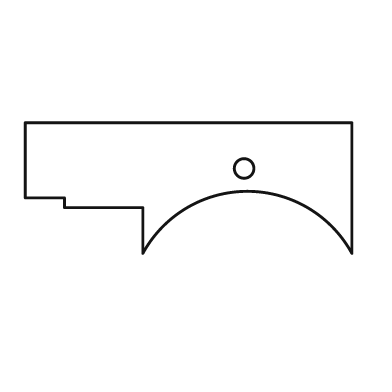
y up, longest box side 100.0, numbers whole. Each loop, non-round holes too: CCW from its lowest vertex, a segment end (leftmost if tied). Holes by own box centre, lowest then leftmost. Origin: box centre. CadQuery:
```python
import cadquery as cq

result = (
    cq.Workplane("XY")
    .moveTo(-14.0, -20.0)
    .threePointArc((18.0, -1.0), (50.0, -20.0))
    .lineTo(50.0, 20.0)
    .lineTo(-50.0, 20.0)
    .lineTo(-50.0, -3.0)
    .lineTo(-38.0, -3.0)
    .lineTo(-38.0, -6.0)
    .lineTo(-14.0, -6.0)
    .close()
    .moveTo(17.0, 6.0)
    .circle(3.0)
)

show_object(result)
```